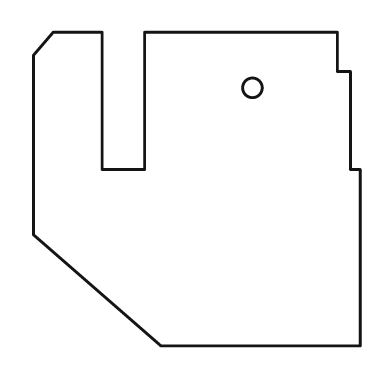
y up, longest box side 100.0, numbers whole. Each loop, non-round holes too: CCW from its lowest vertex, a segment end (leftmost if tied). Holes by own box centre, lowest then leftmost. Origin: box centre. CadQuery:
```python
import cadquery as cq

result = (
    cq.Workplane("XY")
    .moveTo(-11.0, -48.0)
    .lineTo(50.0, -48.0)
    .lineTo(50.0, 6.0)
    .lineTo(47.0, 6.0)
    .lineTo(47.0, 36.0)
    .lineTo(43.0, 36.0)
    .lineTo(43.0, 48.0)
    .lineTo(-16.0, 48.0)
    .lineTo(-16.0, 6.0)
    .lineTo(-29.0, 6.0)
    .lineTo(-29.0, 48.0)
    .lineTo(-44.0, 48.0)
    .lineTo(-50.0, 41.0)
    .lineTo(-50.0, -14.0)
    .close()
    .moveTo(17.0, 31.0)
    .circle(3.0)
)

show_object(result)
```